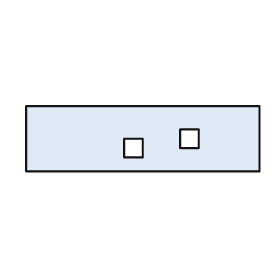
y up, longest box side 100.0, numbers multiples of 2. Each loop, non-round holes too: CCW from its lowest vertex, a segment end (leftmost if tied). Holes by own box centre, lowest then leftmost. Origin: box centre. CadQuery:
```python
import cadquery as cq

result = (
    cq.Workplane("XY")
    .moveTo(-50.0, -14.0)
    .lineTo(50.0, -14.0)
    .lineTo(50.0, 14.0)
    .lineTo(-50.0, 14.0)
    .close()
    .moveTo(-8.0, -8.0)
    .lineTo(0.0, -8.0)
    .lineTo(0.0, 0.0)
    .lineTo(-8.0, 0.0)
    .close()
    .moveTo(16.0, -4.0)
    .lineTo(24.0, -4.0)
    .lineTo(24.0, 4.0)
    .lineTo(16.0, 4.0)
    .close()
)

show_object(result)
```